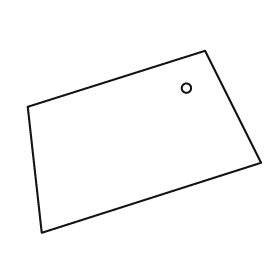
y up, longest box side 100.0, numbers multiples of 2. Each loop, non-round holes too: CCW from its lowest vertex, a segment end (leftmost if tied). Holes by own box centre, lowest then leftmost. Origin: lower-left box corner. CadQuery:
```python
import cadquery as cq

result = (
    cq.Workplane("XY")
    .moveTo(6.0, 0.0)
    .lineTo(100.0, 30.0)
    .lineTo(76.0, 78.0)
    .lineTo(0.0, 54.0)
    .close()
    .moveTo(68.0, 62.0)
    .circle(2.0)
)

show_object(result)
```